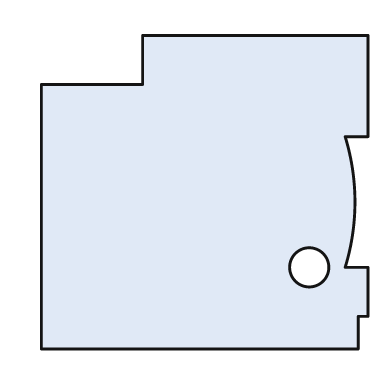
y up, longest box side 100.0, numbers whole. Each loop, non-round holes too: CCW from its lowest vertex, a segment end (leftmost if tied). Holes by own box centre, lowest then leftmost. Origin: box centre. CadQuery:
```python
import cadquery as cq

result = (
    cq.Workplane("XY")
    .moveTo(-50.0, -48.0)
    .lineTo(47.0, -48.0)
    .lineTo(47.0, -38.0)
    .lineTo(50.0, -38.0)
    .lineTo(50.0, -23.0)
    .lineTo(43.0, -23.0)
    .threePointArc((46.0, -3.0), (43.0, 17.0))
    .lineTo(50.0, 17.0)
    .lineTo(50.0, 48.0)
    .lineTo(-19.0, 48.0)
    .lineTo(-19.0, 33.0)
    .lineTo(-50.0, 33.0)
    .close()
    .moveTo(32.0, -23.0)
    .circle(6.0)
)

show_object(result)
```